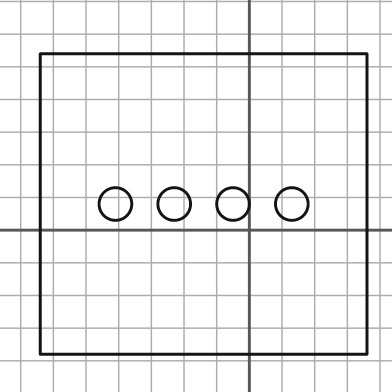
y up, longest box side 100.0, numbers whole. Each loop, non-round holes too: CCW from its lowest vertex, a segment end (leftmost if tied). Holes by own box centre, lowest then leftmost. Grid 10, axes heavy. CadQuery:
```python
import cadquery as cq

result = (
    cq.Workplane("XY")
    .moveTo(-64.0, -38.0)
    .lineTo(36.0, -38.0)
    .lineTo(36.0, 54.0)
    .lineTo(-64.0, 54.0)
    .close()
    .moveTo(-41.0, 8.0)
    .circle(5.0)
    .moveTo(-23.0, 8.0)
    .circle(5.0)
    .moveTo(-5.0, 8.0)
    .circle(5.0)
    .moveTo(13.0, 8.0)
    .circle(5.0)
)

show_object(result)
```